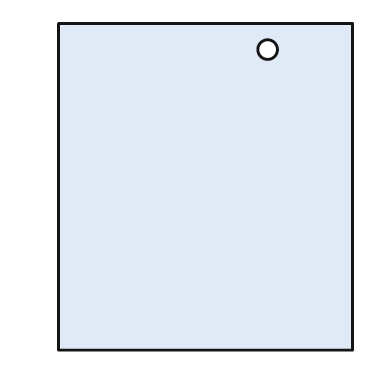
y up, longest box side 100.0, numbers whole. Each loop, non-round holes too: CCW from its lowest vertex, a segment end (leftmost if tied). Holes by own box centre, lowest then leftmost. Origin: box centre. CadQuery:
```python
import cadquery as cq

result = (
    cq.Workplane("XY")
    .moveTo(-45.0, -50.0)
    .lineTo(45.0, -50.0)
    .lineTo(45.0, 50.0)
    .lineTo(-45.0, 50.0)
    .close()
    .moveTo(19.0, 42.0)
    .circle(3.0)
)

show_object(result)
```